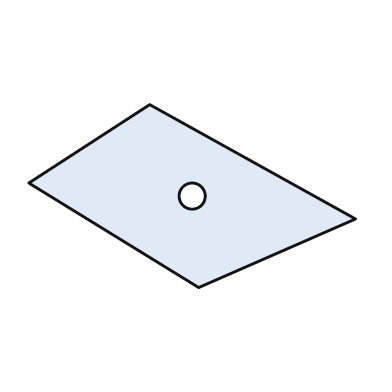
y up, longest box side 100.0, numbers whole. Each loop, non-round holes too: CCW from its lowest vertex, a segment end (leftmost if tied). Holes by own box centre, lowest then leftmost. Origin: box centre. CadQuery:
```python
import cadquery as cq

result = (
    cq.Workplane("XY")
    .moveTo(2.0, -28.0)
    .lineTo(50.0, -7.0)
    .lineTo(-13.0, 28.0)
    .lineTo(-50.0, 4.0)
    .close()
    .moveTo(0.0, 0.0)
    .circle(4.0)
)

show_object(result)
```